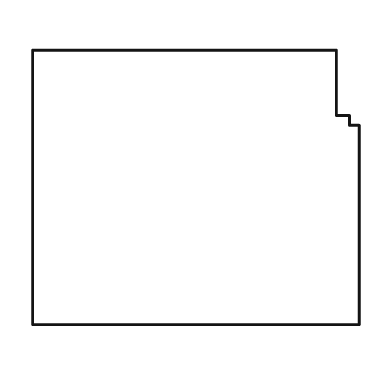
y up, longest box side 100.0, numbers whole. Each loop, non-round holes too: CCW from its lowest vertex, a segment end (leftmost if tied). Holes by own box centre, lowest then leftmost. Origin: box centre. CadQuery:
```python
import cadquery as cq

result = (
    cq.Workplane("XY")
    .moveTo(-50.0, -42.0)
    .lineTo(50.0, -42.0)
    .lineTo(50.0, 19.0)
    .lineTo(47.0, 19.0)
    .lineTo(47.0, 22.0)
    .lineTo(43.0, 22.0)
    .lineTo(43.0, 42.0)
    .lineTo(-50.0, 42.0)
    .close()
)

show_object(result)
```